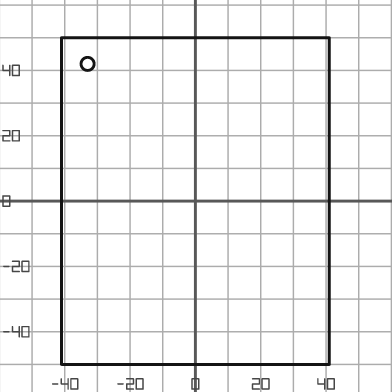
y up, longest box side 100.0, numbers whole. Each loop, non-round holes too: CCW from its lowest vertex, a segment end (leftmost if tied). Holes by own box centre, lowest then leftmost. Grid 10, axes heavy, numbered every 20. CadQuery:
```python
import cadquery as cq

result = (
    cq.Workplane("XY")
    .moveTo(-41.0, -50.0)
    .lineTo(41.0, -50.0)
    .lineTo(41.0, 50.0)
    .lineTo(-41.0, 50.0)
    .close()
    .moveTo(-33.0, 42.0)
    .circle(2.0)
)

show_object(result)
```